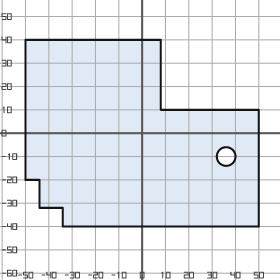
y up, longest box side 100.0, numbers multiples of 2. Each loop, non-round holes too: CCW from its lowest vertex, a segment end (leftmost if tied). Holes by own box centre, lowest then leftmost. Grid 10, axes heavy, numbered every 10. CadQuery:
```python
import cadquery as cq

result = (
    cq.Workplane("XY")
    .moveTo(-34.0, -40.0)
    .lineTo(50.0, -40.0)
    .lineTo(50.0, 10.0)
    .lineTo(8.0, 10.0)
    .lineTo(8.0, 40.0)
    .lineTo(-50.0, 40.0)
    .lineTo(-50.0, -20.0)
    .lineTo(-44.0, -20.0)
    .lineTo(-44.0, -32.0)
    .lineTo(-34.0, -32.0)
    .close()
    .moveTo(36.0, -10.0)
    .circle(4.0)
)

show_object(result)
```